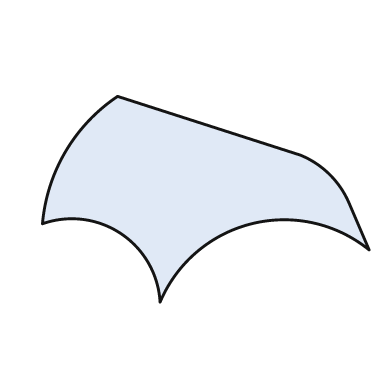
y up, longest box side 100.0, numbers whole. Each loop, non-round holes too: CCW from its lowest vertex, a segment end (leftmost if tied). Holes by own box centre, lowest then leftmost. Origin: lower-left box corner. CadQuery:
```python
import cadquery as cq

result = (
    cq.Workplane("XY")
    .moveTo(36.0, 0.0)
    .threePointArc((64.0, 24.0), (100.0, 16.0))
    .lineTo(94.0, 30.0)
    .threePointArc((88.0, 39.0), (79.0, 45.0))
    .lineTo(23.0, 63.0)
    .threePointArc((7.0, 46.0), (0.0, 24.0))
    .threePointArc((24.0, 21.0), (36.0, 0.0))
    .close()
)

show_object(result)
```